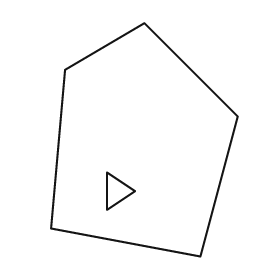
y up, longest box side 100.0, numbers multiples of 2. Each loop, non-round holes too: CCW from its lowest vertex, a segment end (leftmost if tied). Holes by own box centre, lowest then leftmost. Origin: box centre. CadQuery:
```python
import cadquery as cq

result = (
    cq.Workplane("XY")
    .moveTo(24.0, -50.0)
    .lineTo(40.0, 10.0)
    .lineTo(0.0, 50.0)
    .lineTo(-34.0, 30.0)
    .lineTo(-40.0, -38.0)
    .close()
    .moveTo(-16.0, -30.0)
    .lineTo(-4.0, -22.0)
    .lineTo(-16.0, -14.0)
    .close()
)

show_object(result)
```